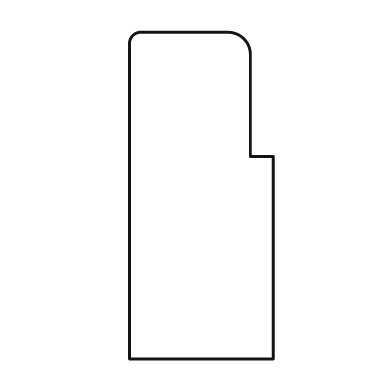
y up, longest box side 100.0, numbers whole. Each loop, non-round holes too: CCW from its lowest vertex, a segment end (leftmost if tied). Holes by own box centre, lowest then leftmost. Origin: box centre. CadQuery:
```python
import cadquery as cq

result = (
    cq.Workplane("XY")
    .moveTo(-22.0, -50.0)
    .lineTo(22.0, -50.0)
    .lineTo(22.0, 12.0)
    .lineTo(15.0, 12.0)
    .lineTo(15.0, 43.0)
    .threePointArc((13.0, 48.0), (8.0, 50.0))
    .lineTo(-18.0, 50.0)
    .threePointArc((-21.0, 49.0), (-22.0, 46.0))
    .close()
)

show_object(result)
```